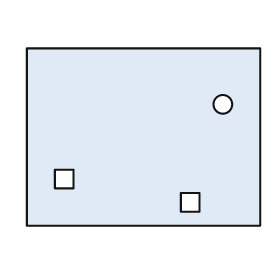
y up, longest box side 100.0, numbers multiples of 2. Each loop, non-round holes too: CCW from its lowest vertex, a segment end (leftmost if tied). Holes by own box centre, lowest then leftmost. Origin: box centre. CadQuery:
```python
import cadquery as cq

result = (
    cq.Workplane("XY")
    .moveTo(-50.0, -38.0)
    .lineTo(50.0, -38.0)
    .lineTo(50.0, 38.0)
    .lineTo(-50.0, 38.0)
    .close()
    .moveTo(16.0, -32.0)
    .lineTo(24.0, -32.0)
    .lineTo(24.0, -24.0)
    .lineTo(16.0, -24.0)
    .close()
    .moveTo(-38.0, -22.0)
    .lineTo(-30.0, -22.0)
    .lineTo(-30.0, -14.0)
    .lineTo(-38.0, -14.0)
    .close()
    .moveTo(34.0, 14.0)
    .circle(4.0)
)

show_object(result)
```